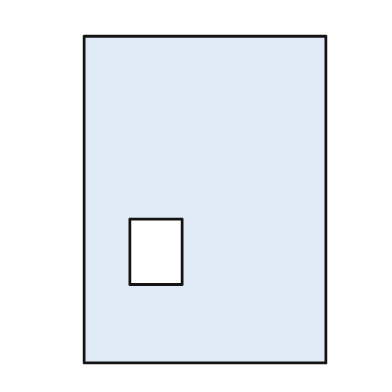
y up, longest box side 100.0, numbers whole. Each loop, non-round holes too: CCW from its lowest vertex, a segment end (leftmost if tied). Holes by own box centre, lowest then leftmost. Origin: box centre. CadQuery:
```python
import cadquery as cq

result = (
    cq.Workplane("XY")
    .moveTo(-37.0, -50.0)
    .lineTo(37.0, -50.0)
    .lineTo(37.0, 50.0)
    .lineTo(-37.0, 50.0)
    .close()
    .moveTo(-23.0, -26.0)
    .lineTo(-7.0, -26.0)
    .lineTo(-7.0, -6.0)
    .lineTo(-23.0, -6.0)
    .close()
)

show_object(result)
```